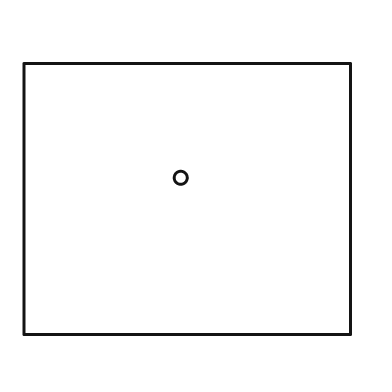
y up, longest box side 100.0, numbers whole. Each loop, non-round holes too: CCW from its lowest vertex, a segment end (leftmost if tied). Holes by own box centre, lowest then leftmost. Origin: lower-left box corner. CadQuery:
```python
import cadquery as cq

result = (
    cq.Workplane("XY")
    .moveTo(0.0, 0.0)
    .lineTo(100.0, 0.0)
    .lineTo(100.0, 83.0)
    .lineTo(0.0, 83.0)
    .close()
    .moveTo(48.0, 48.0)
    .circle(2.0)
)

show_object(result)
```